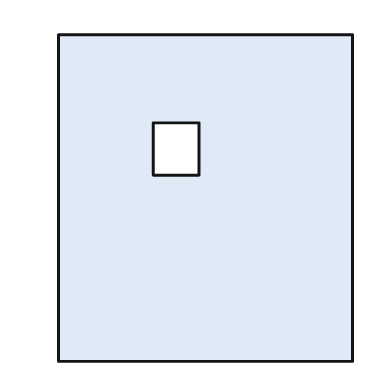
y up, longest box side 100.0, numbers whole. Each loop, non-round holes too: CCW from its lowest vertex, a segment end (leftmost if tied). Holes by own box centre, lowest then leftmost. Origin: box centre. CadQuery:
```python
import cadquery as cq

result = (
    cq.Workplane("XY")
    .moveTo(-45.0, -50.0)
    .lineTo(45.0, -50.0)
    .lineTo(45.0, 50.0)
    .lineTo(-45.0, 50.0)
    .close()
    .moveTo(-16.0, 7.0)
    .lineTo(-2.0, 7.0)
    .lineTo(-2.0, 23.0)
    .lineTo(-16.0, 23.0)
    .close()
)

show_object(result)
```